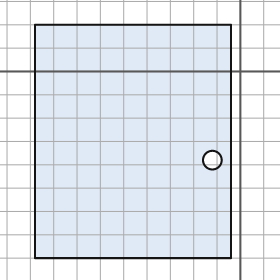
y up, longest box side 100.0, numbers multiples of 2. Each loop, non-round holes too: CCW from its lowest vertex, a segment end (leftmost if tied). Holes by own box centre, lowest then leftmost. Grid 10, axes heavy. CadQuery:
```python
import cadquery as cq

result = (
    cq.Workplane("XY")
    .moveTo(-88.0, -80.0)
    .lineTo(-4.0, -80.0)
    .lineTo(-4.0, 20.0)
    .lineTo(-88.0, 20.0)
    .close()
    .moveTo(-12.0, -38.0)
    .circle(4.0)
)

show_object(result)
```